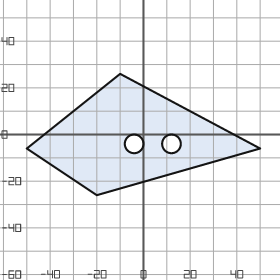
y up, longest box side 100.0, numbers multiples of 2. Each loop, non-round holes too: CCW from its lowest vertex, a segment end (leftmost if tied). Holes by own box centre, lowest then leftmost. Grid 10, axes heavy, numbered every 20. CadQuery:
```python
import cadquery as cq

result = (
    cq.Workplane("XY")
    .moveTo(-20.0, -26.0)
    .lineTo(50.0, -6.0)
    .lineTo(-10.0, 26.0)
    .lineTo(-50.0, -6.0)
    .close()
    .moveTo(-4.0, -4.0)
    .circle(4.0)
    .moveTo(12.0, -4.0)
    .circle(4.0)
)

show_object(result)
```